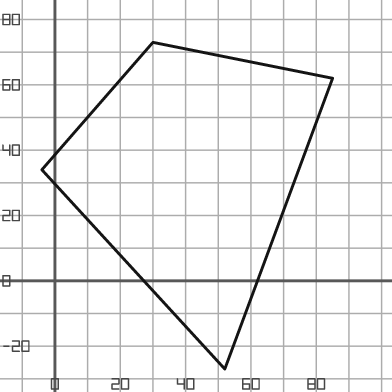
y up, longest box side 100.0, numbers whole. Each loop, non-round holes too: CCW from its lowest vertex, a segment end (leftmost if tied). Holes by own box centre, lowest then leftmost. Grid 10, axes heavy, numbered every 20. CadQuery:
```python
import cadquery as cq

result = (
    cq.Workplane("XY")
    .moveTo(52.0, -27.0)
    .lineTo(85.0, 62.0)
    .lineTo(30.0, 73.0)
    .lineTo(-4.0, 34.0)
    .close()
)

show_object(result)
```